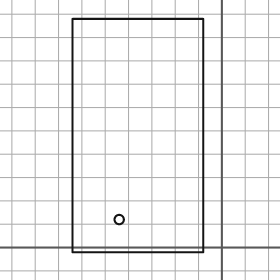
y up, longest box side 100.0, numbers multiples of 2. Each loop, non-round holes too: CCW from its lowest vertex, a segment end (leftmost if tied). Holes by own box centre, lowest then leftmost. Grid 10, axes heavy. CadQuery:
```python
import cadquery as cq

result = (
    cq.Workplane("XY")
    .moveTo(-64.0, -2.0)
    .lineTo(-8.0, -2.0)
    .lineTo(-8.0, 98.0)
    .lineTo(-64.0, 98.0)
    .close()
    .moveTo(-44.0, 12.0)
    .circle(2.0)
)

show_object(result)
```